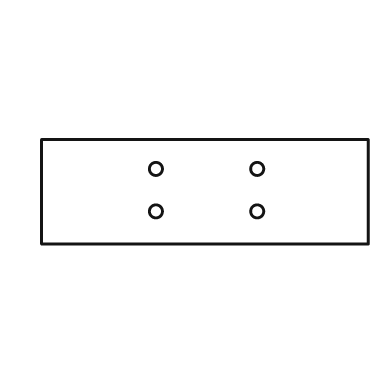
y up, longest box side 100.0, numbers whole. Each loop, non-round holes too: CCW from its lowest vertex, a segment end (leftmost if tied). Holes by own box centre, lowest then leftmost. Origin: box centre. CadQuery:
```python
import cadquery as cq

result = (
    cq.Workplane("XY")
    .moveTo(-50.0, -16.0)
    .lineTo(50.0, -16.0)
    .lineTo(50.0, 16.0)
    .lineTo(-50.0, 16.0)
    .close()
    .moveTo(-15.0, -6.0)
    .circle(2.0)
    .moveTo(16.0, -6.0)
    .circle(2.0)
    .moveTo(-15.0, 7.0)
    .circle(2.0)
    .moveTo(16.0, 7.0)
    .circle(2.0)
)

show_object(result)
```